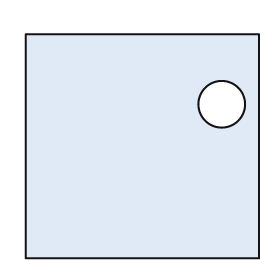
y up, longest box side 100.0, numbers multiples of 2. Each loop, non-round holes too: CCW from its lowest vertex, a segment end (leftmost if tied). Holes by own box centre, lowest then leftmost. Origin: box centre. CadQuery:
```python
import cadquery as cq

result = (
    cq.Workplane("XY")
    .moveTo(-50.0, -48.0)
    .lineTo(50.0, -48.0)
    .lineTo(50.0, 48.0)
    .lineTo(-50.0, 48.0)
    .close()
    .moveTo(34.0, 18.0)
    .circle(10.0)
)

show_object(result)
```